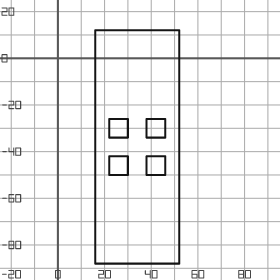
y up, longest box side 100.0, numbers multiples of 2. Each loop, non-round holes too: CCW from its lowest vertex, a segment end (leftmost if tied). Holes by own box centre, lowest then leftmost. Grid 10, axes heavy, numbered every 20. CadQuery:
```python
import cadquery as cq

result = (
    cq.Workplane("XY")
    .moveTo(16.0, -88.0)
    .lineTo(52.0, -88.0)
    .lineTo(52.0, 12.0)
    .lineTo(16.0, 12.0)
    .close()
    .moveTo(22.0, -50.0)
    .lineTo(30.0, -50.0)
    .lineTo(30.0, -42.0)
    .lineTo(22.0, -42.0)
    .close()
    .moveTo(38.0, -50.0)
    .lineTo(46.0, -50.0)
    .lineTo(46.0, -42.0)
    .lineTo(38.0, -42.0)
    .close()
    .moveTo(22.0, -34.0)
    .lineTo(30.0, -34.0)
    .lineTo(30.0, -26.0)
    .lineTo(22.0, -26.0)
    .close()
    .moveTo(38.0, -34.0)
    .lineTo(46.0, -34.0)
    .lineTo(46.0, -26.0)
    .lineTo(38.0, -26.0)
    .close()
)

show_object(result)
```